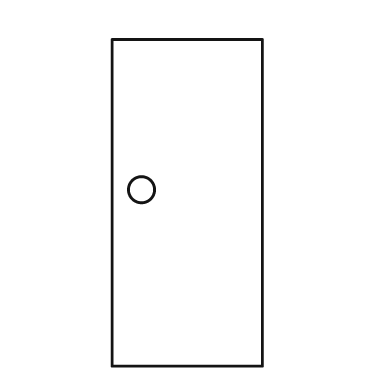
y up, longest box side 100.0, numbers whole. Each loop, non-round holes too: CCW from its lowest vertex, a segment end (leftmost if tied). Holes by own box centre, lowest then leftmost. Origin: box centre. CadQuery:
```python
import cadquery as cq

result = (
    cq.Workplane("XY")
    .moveTo(-23.0, -50.0)
    .lineTo(23.0, -50.0)
    .lineTo(23.0, 50.0)
    .lineTo(-23.0, 50.0)
    .close()
    .moveTo(-14.0, 4.0)
    .circle(4.0)
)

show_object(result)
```